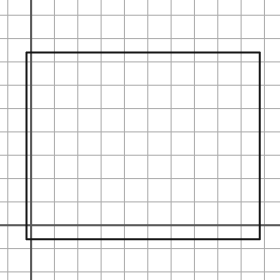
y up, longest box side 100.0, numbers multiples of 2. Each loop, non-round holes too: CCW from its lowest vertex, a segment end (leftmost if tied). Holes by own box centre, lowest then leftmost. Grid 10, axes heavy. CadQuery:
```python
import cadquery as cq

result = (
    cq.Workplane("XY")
    .moveTo(-2.0, -6.0)
    .lineTo(98.0, -6.0)
    .lineTo(98.0, 74.0)
    .lineTo(-2.0, 74.0)
    .close()
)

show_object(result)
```